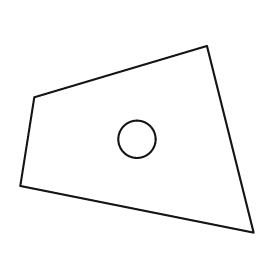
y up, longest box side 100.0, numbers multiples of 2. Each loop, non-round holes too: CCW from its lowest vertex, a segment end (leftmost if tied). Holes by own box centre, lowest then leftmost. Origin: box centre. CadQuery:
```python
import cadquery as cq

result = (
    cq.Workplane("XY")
    .moveTo(50.0, -40.0)
    .lineTo(30.0, 40.0)
    .lineTo(-44.0, 18.0)
    .lineTo(-50.0, -20.0)
    .close()
    .moveTo(0.0, 0.0)
    .circle(8.0)
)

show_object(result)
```